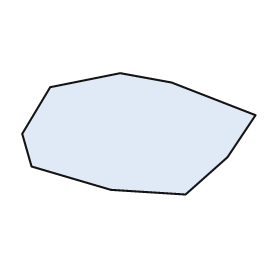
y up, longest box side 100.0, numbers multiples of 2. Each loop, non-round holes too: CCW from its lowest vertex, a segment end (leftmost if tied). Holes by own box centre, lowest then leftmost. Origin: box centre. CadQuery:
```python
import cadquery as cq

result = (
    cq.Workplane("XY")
    .moveTo(20.0, -26.0)
    .lineTo(38.0, -10.0)
    .lineTo(50.0, 8.0)
    .lineTo(14.0, 22.0)
    .lineTo(-8.0, 26.0)
    .lineTo(-38.0, 20.0)
    .lineTo(-50.0, 0.0)
    .lineTo(-46.0, -14.0)
    .lineTo(-12.0, -24.0)
    .close()
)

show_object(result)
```